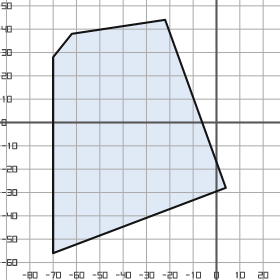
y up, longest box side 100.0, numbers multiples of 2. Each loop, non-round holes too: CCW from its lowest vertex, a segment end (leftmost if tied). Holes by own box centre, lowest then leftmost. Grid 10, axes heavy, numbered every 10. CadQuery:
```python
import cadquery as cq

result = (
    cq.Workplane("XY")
    .moveTo(-70.0, -56.0)
    .lineTo(4.0, -28.0)
    .lineTo(-22.0, 44.0)
    .lineTo(-62.0, 38.0)
    .lineTo(-70.0, 28.0)
    .close()
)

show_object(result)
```